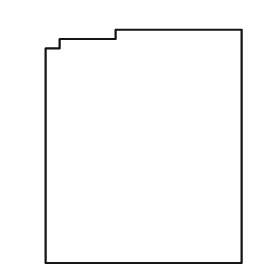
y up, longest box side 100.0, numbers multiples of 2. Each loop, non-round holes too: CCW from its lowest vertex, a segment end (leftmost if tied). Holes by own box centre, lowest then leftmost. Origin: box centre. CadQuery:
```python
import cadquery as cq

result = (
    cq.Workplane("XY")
    .moveTo(-42.0, -50.0)
    .lineTo(42.0, -50.0)
    .lineTo(42.0, 50.0)
    .lineTo(-12.0, 50.0)
    .lineTo(-12.0, 46.0)
    .lineTo(-36.0, 46.0)
    .lineTo(-36.0, 42.0)
    .lineTo(-42.0, 42.0)
    .close()
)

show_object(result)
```